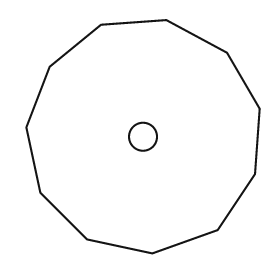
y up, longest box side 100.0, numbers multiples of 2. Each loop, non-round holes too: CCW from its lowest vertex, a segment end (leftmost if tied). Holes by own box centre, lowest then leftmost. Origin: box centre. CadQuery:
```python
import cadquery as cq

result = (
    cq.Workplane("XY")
    .moveTo(4.0, -50.0)
    .lineTo(32.0, -40.0)
    .lineTo(48.0, -16.0)
    .lineTo(50.0, 12.0)
    .lineTo(36.0, 36.0)
    .lineTo(10.0, 50.0)
    .lineTo(-18.0, 48.0)
    .lineTo(-40.0, 30.0)
    .lineTo(-50.0, 4.0)
    .lineTo(-44.0, -24.0)
    .lineTo(-24.0, -44.0)
    .close()
    .moveTo(0.0, 0.0)
    .circle(6.0)
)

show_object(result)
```